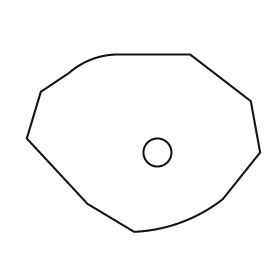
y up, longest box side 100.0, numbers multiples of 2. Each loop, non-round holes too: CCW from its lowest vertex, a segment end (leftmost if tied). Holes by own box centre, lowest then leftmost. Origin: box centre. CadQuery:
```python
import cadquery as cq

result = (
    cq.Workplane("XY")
    .moveTo(-4.0, -38.0)
    .threePointArc((16.0, -34.0), (34.0, -24.0))
    .lineTo(50.0, -4.0)
    .lineTo(46.0, 18.0)
    .lineTo(20.0, 38.0)
    .lineTo(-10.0, 38.0)
    .threePointArc((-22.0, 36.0), (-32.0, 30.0))
    .lineTo(-44.0, 22.0)
    .lineTo(-50.0, 2.0)
    .lineTo(-24.0, -26.0)
    .close()
    .moveTo(6.0, -4.0)
    .circle(6.0)
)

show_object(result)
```